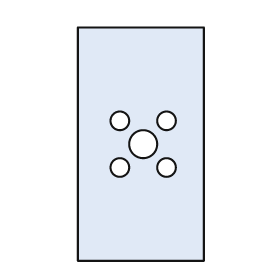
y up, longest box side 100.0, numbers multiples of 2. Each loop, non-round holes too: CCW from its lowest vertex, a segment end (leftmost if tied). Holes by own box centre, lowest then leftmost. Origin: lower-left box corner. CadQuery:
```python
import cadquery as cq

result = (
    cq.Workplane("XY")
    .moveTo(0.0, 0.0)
    .lineTo(54.0, 0.0)
    .lineTo(54.0, 100.0)
    .lineTo(0.0, 100.0)
    .close()
    .moveTo(18.0, 40.0)
    .circle(4.0)
    .moveTo(38.0, 40.0)
    .circle(4.0)
    .moveTo(28.0, 50.0)
    .circle(6.0)
    .moveTo(18.0, 60.0)
    .circle(4.0)
    .moveTo(38.0, 60.0)
    .circle(4.0)
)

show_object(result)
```